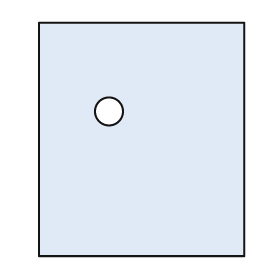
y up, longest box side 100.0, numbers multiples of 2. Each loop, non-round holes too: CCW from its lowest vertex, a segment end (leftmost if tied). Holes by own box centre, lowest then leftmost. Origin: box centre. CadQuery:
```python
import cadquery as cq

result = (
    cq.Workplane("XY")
    .moveTo(-44.0, -50.0)
    .lineTo(44.0, -50.0)
    .lineTo(44.0, 50.0)
    .lineTo(-44.0, 50.0)
    .close()
    .moveTo(-14.0, 12.0)
    .circle(6.0)
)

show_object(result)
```